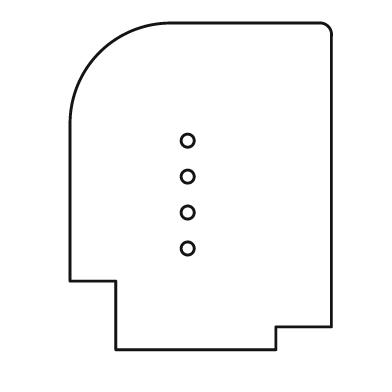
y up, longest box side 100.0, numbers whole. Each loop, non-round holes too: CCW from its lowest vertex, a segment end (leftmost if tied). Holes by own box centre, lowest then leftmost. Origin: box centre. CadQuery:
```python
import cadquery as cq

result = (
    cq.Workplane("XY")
    .moveTo(-26.0, -50.0)
    .lineTo(23.0, -50.0)
    .lineTo(23.0, -43.0)
    .lineTo(40.0, -43.0)
    .lineTo(40.0, 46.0)
    .threePointArc((39.0, 49.0), (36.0, 50.0))
    .lineTo(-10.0, 50.0)
    .threePointArc((-31.0, 41.0), (-40.0, 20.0))
    .lineTo(-40.0, -29.0)
    .lineTo(-26.0, -29.0)
    .close()
    .moveTo(-4.0, -19.0)
    .circle(2.0)
    .moveTo(-4.0, -8.0)
    .circle(2.0)
    .moveTo(-4.0, 3.0)
    .circle(2.0)
    .moveTo(-4.0, 14.0)
    .circle(2.0)
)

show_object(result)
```